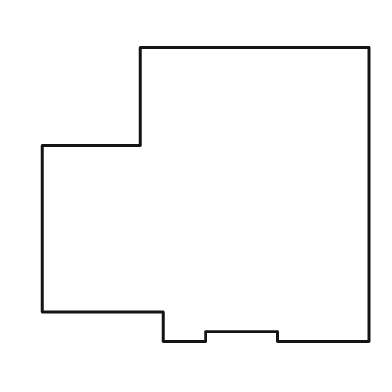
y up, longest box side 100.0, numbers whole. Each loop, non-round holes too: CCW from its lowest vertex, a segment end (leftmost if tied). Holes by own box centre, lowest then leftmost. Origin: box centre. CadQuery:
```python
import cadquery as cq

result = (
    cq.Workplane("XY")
    .moveTo(-13.0, -45.0)
    .lineTo(0.0, -45.0)
    .lineTo(0.0, -42.0)
    .lineTo(22.0, -42.0)
    .lineTo(22.0, -45.0)
    .lineTo(50.0, -45.0)
    .lineTo(50.0, 45.0)
    .lineTo(-20.0, 45.0)
    .lineTo(-20.0, 15.0)
    .lineTo(-50.0, 15.0)
    .lineTo(-50.0, -36.0)
    .lineTo(-13.0, -36.0)
    .close()
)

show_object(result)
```